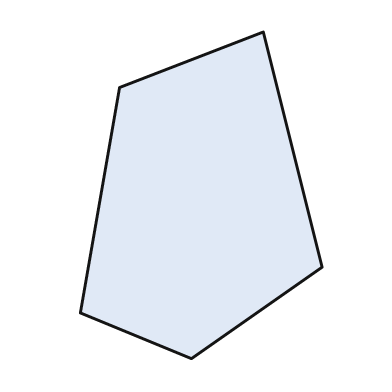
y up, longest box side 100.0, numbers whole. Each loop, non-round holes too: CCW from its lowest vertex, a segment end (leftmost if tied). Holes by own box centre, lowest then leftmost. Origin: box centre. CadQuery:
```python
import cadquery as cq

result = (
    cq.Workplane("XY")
    .moveTo(-3.0, -50.0)
    .lineTo(37.0, -22.0)
    .lineTo(19.0, 50.0)
    .lineTo(-25.0, 33.0)
    .lineTo(-37.0, -36.0)
    .close()
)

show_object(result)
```